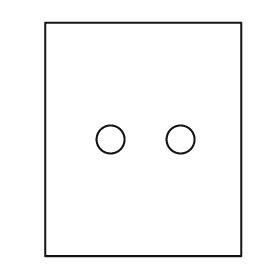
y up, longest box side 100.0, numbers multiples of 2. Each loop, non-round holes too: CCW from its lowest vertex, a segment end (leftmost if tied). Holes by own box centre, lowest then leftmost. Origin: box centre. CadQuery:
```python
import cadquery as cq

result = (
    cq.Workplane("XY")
    .moveTo(-42.0, -50.0)
    .lineTo(42.0, -50.0)
    .lineTo(42.0, 50.0)
    .lineTo(-42.0, 50.0)
    .close()
    .moveTo(-14.0, 0.0)
    .circle(6.0)
    .moveTo(16.0, 0.0)
    .circle(6.0)
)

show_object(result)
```